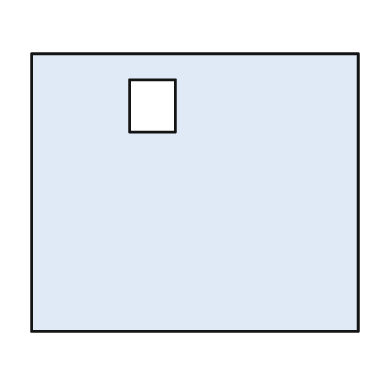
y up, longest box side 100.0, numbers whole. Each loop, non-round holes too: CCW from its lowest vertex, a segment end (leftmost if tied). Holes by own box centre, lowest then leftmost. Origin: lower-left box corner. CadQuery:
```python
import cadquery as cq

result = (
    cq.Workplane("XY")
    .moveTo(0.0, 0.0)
    .lineTo(100.0, 0.0)
    .lineTo(100.0, 85.0)
    .lineTo(0.0, 85.0)
    .close()
    .moveTo(30.0, 61.0)
    .lineTo(44.0, 61.0)
    .lineTo(44.0, 77.0)
    .lineTo(30.0, 77.0)
    .close()
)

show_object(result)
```